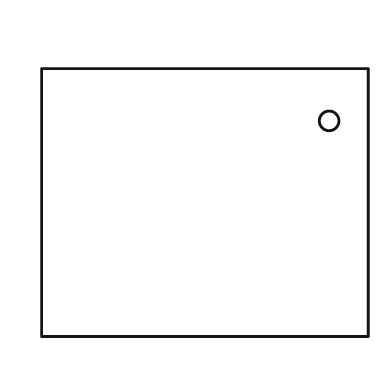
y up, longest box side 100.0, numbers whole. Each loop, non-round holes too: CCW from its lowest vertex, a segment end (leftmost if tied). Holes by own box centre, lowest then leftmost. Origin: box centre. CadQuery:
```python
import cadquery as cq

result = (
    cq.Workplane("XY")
    .moveTo(-50.0, -41.0)
    .lineTo(50.0, -41.0)
    .lineTo(50.0, 41.0)
    .lineTo(-50.0, 41.0)
    .close()
    .moveTo(38.0, 25.0)
    .circle(3.0)
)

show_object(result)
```